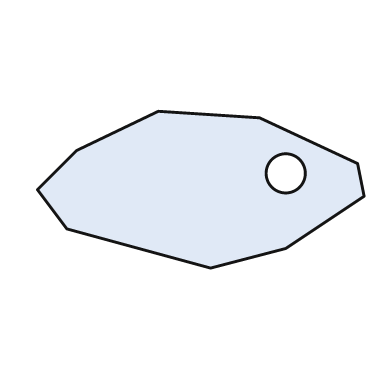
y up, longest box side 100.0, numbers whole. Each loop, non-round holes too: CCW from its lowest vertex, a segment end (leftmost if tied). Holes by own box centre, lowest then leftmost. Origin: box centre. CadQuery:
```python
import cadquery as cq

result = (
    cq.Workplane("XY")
    .moveTo(3.0, -24.0)
    .lineTo(26.0, -18.0)
    .lineTo(50.0, -2.0)
    .lineTo(48.0, 8.0)
    .lineTo(18.0, 22.0)
    .lineTo(-13.0, 24.0)
    .lineTo(-38.0, 12.0)
    .lineTo(-50.0, 0.0)
    .lineTo(-41.0, -12.0)
    .close()
    .moveTo(26.0, 5.0)
    .circle(6.0)
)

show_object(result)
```